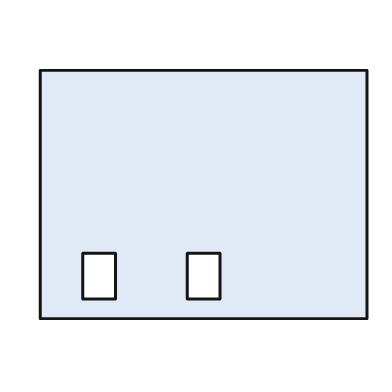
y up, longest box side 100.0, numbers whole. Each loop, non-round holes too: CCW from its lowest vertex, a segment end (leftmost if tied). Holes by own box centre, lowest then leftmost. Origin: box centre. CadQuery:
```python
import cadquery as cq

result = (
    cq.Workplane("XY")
    .moveTo(-50.0, -38.0)
    .lineTo(50.0, -38.0)
    .lineTo(50.0, 38.0)
    .lineTo(-50.0, 38.0)
    .close()
    .moveTo(-37.0, -32.0)
    .lineTo(-27.0, -32.0)
    .lineTo(-27.0, -18.0)
    .lineTo(-37.0, -18.0)
    .close()
    .moveTo(-5.0, -32.0)
    .lineTo(5.0, -32.0)
    .lineTo(5.0, -18.0)
    .lineTo(-5.0, -18.0)
    .close()
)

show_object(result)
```